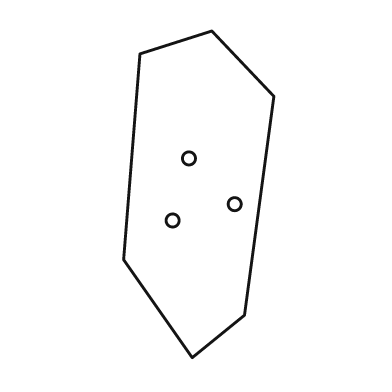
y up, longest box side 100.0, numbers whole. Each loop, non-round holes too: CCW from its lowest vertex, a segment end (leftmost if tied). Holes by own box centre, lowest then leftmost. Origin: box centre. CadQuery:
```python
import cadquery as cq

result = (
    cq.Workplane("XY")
    .moveTo(-2.0, -50.0)
    .lineTo(14.0, -37.0)
    .lineTo(23.0, 30.0)
    .lineTo(4.0, 50.0)
    .lineTo(-18.0, 43.0)
    .lineTo(-23.0, -20.0)
    .close()
    .moveTo(-8.0, -8.0)
    .circle(2.0)
    .moveTo(11.0, -3.0)
    .circle(2.0)
    .moveTo(-3.0, 11.0)
    .circle(2.0)
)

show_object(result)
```